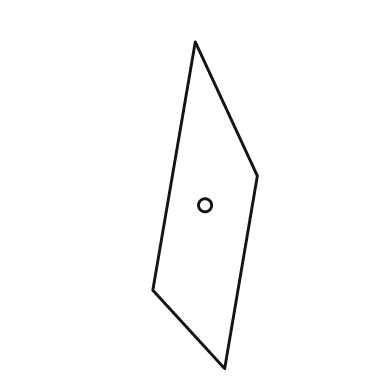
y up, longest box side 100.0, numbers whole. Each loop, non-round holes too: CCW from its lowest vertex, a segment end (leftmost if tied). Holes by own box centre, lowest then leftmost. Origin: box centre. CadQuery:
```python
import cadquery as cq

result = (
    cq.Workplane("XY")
    .moveTo(6.0, -50.0)
    .lineTo(16.0, 9.0)
    .lineTo(-3.0, 50.0)
    .lineTo(-16.0, -26.0)
    .close()
    .moveTo(0.0, 0.0)
    .circle(2.0)
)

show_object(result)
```